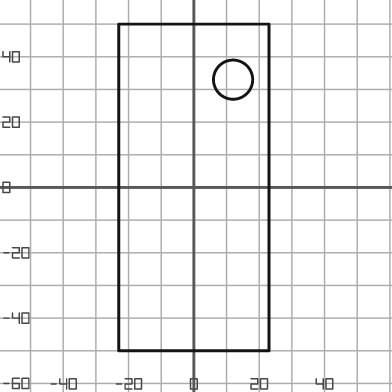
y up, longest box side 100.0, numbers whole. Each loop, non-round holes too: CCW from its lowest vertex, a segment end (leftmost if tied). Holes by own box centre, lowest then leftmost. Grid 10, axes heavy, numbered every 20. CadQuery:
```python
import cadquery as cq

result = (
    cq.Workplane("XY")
    .moveTo(-23.0, -50.0)
    .lineTo(23.0, -50.0)
    .lineTo(23.0, 50.0)
    .lineTo(-23.0, 50.0)
    .close()
    .moveTo(12.0, 33.0)
    .circle(6.0)
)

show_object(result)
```